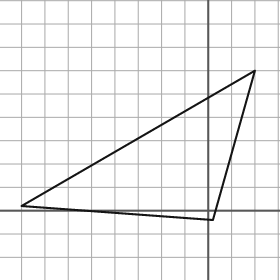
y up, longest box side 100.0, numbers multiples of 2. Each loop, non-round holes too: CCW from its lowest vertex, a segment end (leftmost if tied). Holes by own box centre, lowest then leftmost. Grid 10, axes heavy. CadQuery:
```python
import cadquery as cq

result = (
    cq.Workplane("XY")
    .moveTo(2.0, -4.0)
    .lineTo(20.0, 60.0)
    .lineTo(-80.0, 2.0)
    .close()
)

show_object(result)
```